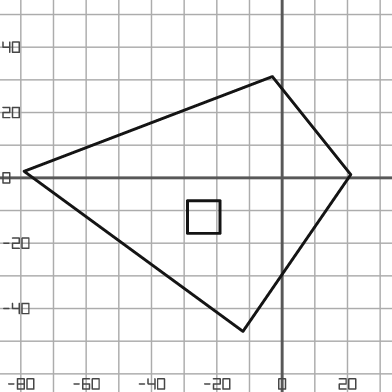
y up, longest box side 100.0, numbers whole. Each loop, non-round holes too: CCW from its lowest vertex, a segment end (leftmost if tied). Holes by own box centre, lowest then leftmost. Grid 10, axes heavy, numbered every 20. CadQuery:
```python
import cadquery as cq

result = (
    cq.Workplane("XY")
    .moveTo(-12.0, -47.0)
    .lineTo(21.0, 1.0)
    .lineTo(-3.0, 31.0)
    .lineTo(-79.0, 2.0)
    .close()
    .moveTo(-29.0, -17.0)
    .lineTo(-19.0, -17.0)
    .lineTo(-19.0, -7.0)
    .lineTo(-29.0, -7.0)
    .close()
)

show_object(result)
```